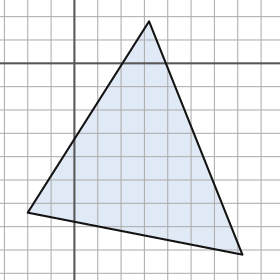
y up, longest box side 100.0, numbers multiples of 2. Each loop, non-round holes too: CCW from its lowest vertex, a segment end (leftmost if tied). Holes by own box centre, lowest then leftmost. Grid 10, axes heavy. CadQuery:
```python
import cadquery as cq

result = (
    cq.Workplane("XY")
    .moveTo(72.0, -82.0)
    .lineTo(32.0, 18.0)
    .lineTo(-20.0, -64.0)
    .close()
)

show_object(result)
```